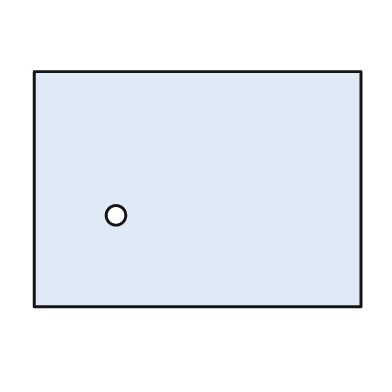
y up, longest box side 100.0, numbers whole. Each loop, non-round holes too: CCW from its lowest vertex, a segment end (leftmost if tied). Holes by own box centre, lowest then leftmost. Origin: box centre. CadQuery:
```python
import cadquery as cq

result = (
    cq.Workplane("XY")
    .moveTo(-50.0, -36.0)
    .lineTo(50.0, -36.0)
    .lineTo(50.0, 36.0)
    .lineTo(-50.0, 36.0)
    .close()
    .moveTo(-25.0, -8.0)
    .circle(3.0)
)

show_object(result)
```